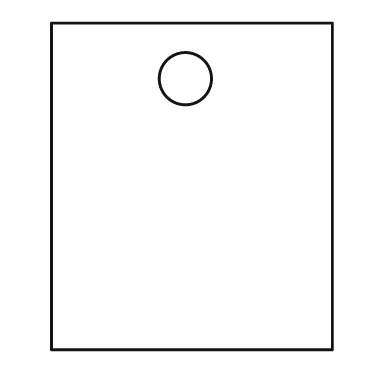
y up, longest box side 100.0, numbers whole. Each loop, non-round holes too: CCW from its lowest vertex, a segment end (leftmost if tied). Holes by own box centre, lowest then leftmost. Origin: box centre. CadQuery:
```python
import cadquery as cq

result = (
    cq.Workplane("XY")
    .moveTo(-43.0, -50.0)
    .lineTo(43.0, -50.0)
    .lineTo(43.0, 50.0)
    .lineTo(-43.0, 50.0)
    .close()
    .moveTo(-2.0, 33.0)
    .circle(8.0)
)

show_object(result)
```